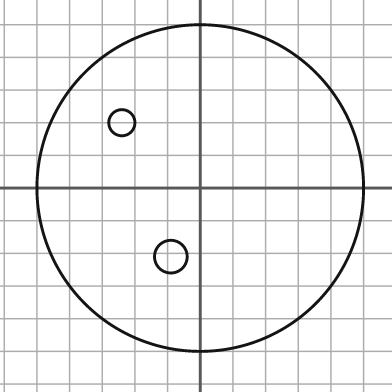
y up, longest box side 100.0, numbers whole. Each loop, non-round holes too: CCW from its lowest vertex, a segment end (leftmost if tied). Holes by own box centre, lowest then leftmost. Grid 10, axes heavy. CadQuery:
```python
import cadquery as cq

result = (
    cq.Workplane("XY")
    .moveTo(0.0, 0.0)
    .circle(50.0)
    .moveTo(-9.0, -21.0)
    .circle(5.0)
    .moveTo(-24.0, 20.0)
    .circle(4.0)
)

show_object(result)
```